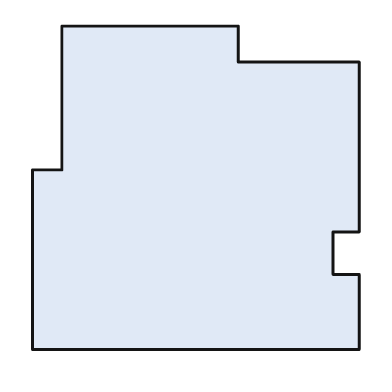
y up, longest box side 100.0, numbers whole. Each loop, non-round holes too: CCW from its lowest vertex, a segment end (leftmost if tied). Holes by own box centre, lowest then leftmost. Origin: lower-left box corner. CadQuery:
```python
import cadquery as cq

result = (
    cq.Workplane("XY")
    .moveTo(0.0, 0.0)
    .lineTo(100.0, 0.0)
    .lineTo(100.0, 23.0)
    .lineTo(92.0, 23.0)
    .lineTo(92.0, 36.0)
    .lineTo(100.0, 36.0)
    .lineTo(100.0, 88.0)
    .lineTo(63.0, 88.0)
    .lineTo(63.0, 99.0)
    .lineTo(9.0, 99.0)
    .lineTo(9.0, 55.0)
    .lineTo(0.0, 55.0)
    .close()
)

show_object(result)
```